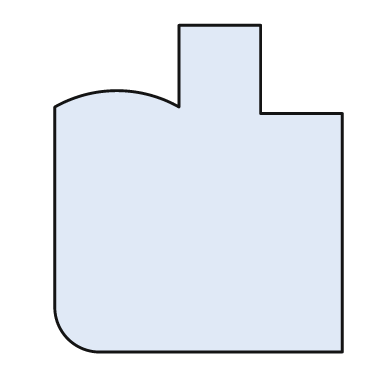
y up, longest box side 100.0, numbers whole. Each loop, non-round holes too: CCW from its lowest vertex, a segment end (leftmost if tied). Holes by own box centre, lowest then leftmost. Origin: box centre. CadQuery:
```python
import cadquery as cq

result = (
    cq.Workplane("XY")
    .moveTo(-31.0, -50.0)
    .lineTo(44.0, -50.0)
    .lineTo(44.0, 23.0)
    .lineTo(19.0, 23.0)
    .lineTo(19.0, 50.0)
    .lineTo(-6.0, 50.0)
    .lineTo(-6.0, 25.0)
    .threePointArc((-25.0, 30.0), (-44.0, 25.0))
    .lineTo(-44.0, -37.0)
    .threePointArc((-40.0, -46.0), (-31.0, -50.0))
    .close()
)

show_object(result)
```